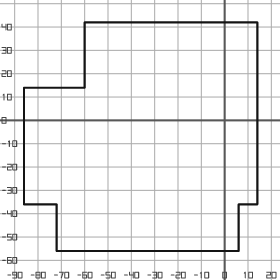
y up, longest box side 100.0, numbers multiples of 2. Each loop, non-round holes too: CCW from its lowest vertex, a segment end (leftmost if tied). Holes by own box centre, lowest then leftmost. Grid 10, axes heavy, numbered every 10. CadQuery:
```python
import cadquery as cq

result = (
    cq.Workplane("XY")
    .moveTo(-72.0, -56.0)
    .lineTo(6.0, -56.0)
    .lineTo(6.0, -36.0)
    .lineTo(14.0, -36.0)
    .lineTo(14.0, 42.0)
    .lineTo(-60.0, 42.0)
    .lineTo(-60.0, 14.0)
    .lineTo(-86.0, 14.0)
    .lineTo(-86.0, -36.0)
    .lineTo(-72.0, -36.0)
    .close()
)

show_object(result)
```